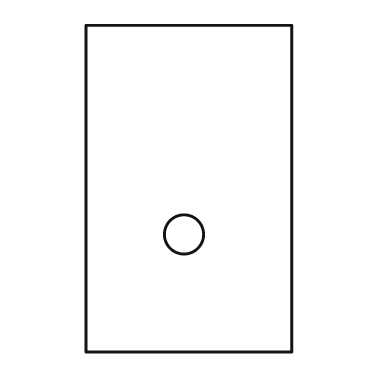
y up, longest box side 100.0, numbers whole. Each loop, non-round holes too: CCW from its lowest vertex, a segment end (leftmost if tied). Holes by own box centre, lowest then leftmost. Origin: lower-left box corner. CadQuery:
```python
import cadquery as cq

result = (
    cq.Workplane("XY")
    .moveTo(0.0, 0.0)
    .lineTo(63.0, 0.0)
    .lineTo(63.0, 100.0)
    .lineTo(0.0, 100.0)
    .close()
    .moveTo(30.0, 36.0)
    .circle(6.0)
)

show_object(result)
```